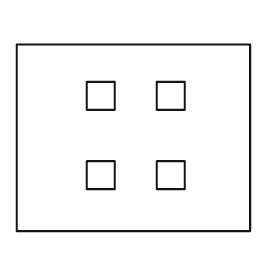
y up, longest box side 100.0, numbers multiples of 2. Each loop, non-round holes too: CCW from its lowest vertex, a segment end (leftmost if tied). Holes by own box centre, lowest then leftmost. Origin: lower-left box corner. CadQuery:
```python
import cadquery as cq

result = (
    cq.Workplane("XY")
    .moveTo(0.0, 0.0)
    .lineTo(100.0, 0.0)
    .lineTo(100.0, 80.0)
    .lineTo(0.0, 80.0)
    .close()
    .moveTo(30.0, 18.0)
    .lineTo(42.0, 18.0)
    .lineTo(42.0, 30.0)
    .lineTo(30.0, 30.0)
    .close()
    .moveTo(60.0, 18.0)
    .lineTo(72.0, 18.0)
    .lineTo(72.0, 30.0)
    .lineTo(60.0, 30.0)
    .close()
    .moveTo(30.0, 52.0)
    .lineTo(42.0, 52.0)
    .lineTo(42.0, 64.0)
    .lineTo(30.0, 64.0)
    .close()
    .moveTo(60.0, 52.0)
    .lineTo(72.0, 52.0)
    .lineTo(72.0, 64.0)
    .lineTo(60.0, 64.0)
    .close()
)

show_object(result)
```